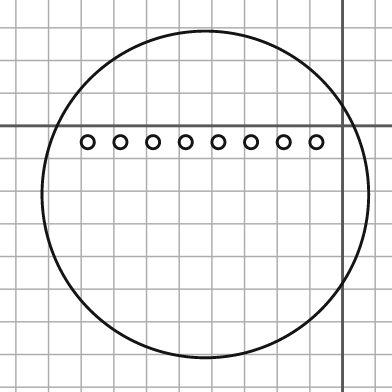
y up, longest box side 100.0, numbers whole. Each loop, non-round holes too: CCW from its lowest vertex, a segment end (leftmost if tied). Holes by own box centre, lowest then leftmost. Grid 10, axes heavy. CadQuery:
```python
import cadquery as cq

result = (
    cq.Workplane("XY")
    .moveTo(-42.0, -21.0)
    .circle(50.0)
    .moveTo(-78.0, -5.0)
    .circle(2.0)
    .moveTo(-68.0, -5.0)
    .circle(2.0)
    .moveTo(-58.0, -5.0)
    .circle(2.0)
    .moveTo(-48.0, -5.0)
    .circle(2.0)
    .moveTo(-38.0, -5.0)
    .circle(2.0)
    .moveTo(-28.0, -5.0)
    .circle(2.0)
    .moveTo(-18.0, -5.0)
    .circle(2.0)
    .moveTo(-8.0, -5.0)
    .circle(2.0)
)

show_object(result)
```